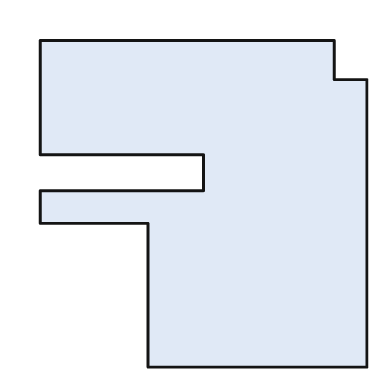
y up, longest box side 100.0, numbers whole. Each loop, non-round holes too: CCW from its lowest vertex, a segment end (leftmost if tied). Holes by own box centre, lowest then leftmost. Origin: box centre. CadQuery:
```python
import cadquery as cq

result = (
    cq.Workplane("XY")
    .moveTo(-17.0, -50.0)
    .lineTo(50.0, -50.0)
    .lineTo(50.0, 38.0)
    .lineTo(40.0, 38.0)
    .lineTo(40.0, 50.0)
    .lineTo(-50.0, 50.0)
    .lineTo(-50.0, 15.0)
    .lineTo(0.0, 15.0)
    .lineTo(0.0, 4.0)
    .lineTo(-50.0, 4.0)
    .lineTo(-50.0, -6.0)
    .lineTo(-17.0, -6.0)
    .close()
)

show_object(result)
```